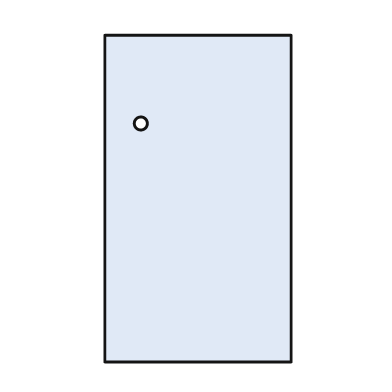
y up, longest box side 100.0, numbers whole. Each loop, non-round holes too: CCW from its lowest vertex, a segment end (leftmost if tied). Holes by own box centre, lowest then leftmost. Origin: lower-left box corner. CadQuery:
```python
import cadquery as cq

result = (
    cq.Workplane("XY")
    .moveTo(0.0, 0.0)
    .lineTo(57.0, 0.0)
    .lineTo(57.0, 100.0)
    .lineTo(0.0, 100.0)
    .close()
    .moveTo(11.0, 73.0)
    .circle(2.0)
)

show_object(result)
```